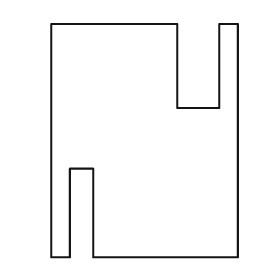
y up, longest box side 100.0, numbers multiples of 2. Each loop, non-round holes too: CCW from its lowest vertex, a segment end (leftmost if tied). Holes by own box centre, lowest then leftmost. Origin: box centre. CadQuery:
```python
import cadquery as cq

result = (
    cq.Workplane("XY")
    .moveTo(-40.0, -50.0)
    .lineTo(-32.0, -50.0)
    .lineTo(-32.0, -12.0)
    .lineTo(-22.0, -12.0)
    .lineTo(-22.0, -50.0)
    .lineTo(40.0, -50.0)
    .lineTo(40.0, 50.0)
    .lineTo(32.0, 50.0)
    .lineTo(32.0, 14.0)
    .lineTo(14.0, 14.0)
    .lineTo(14.0, 50.0)
    .lineTo(-40.0, 50.0)
    .close()
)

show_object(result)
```